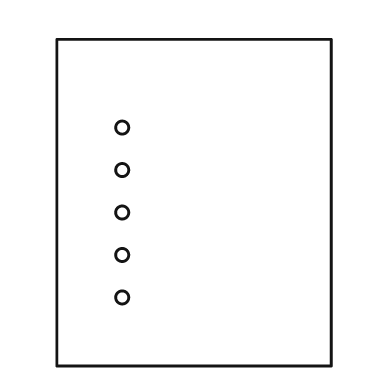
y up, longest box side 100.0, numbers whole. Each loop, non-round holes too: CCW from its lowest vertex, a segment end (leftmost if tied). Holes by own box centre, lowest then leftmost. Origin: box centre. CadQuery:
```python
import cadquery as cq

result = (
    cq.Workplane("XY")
    .moveTo(-42.0, -50.0)
    .lineTo(42.0, -50.0)
    .lineTo(42.0, 50.0)
    .lineTo(-42.0, 50.0)
    .close()
    .moveTo(-22.0, -29.0)
    .circle(2.0)
    .moveTo(-22.0, -16.0)
    .circle(2.0)
    .moveTo(-22.0, -3.0)
    .circle(2.0)
    .moveTo(-22.0, 10.0)
    .circle(2.0)
    .moveTo(-22.0, 23.0)
    .circle(2.0)
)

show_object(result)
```